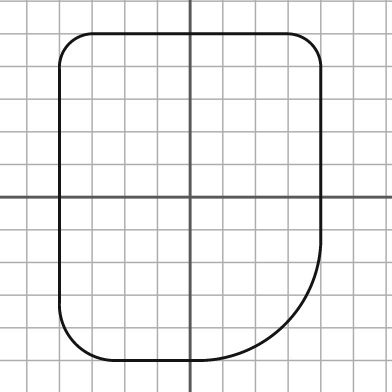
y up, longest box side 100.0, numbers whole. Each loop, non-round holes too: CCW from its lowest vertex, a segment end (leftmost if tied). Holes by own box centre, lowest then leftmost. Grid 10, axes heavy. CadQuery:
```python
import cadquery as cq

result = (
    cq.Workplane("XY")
    .moveTo(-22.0, -50.0)
    .lineTo(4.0, -50.0)
    .threePointArc((29.0, -39.0), (40.0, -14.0))
    .lineTo(40.0, 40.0)
    .threePointArc((37.0, 47.0), (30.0, 50.0))
    .lineTo(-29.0, 50.0)
    .threePointArc((-37.0, 47.0), (-40.0, 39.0))
    .lineTo(-40.0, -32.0)
    .threePointArc((-35.0, -45.0), (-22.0, -50.0))
    .close()
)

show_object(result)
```